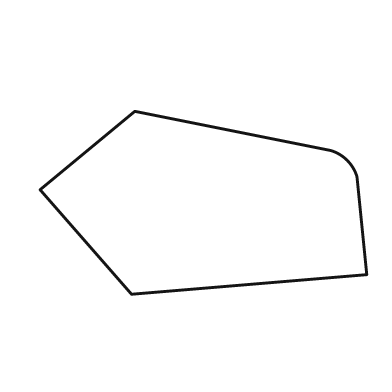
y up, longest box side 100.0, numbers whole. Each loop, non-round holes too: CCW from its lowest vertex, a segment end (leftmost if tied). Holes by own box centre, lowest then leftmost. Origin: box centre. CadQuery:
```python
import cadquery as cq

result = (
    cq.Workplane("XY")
    .moveTo(-22.0, -28.0)
    .lineTo(50.0, -22.0)
    .lineTo(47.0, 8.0)
    .threePointArc((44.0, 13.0), (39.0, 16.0))
    .lineTo(-21.0, 28.0)
    .lineTo(-50.0, 4.0)
    .close()
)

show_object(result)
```